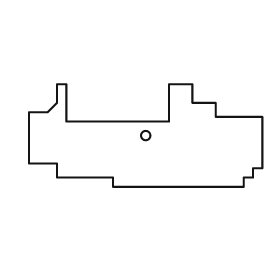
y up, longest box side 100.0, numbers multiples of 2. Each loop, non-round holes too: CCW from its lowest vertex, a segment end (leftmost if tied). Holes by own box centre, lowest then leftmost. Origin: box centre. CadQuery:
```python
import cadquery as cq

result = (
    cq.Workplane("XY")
    .moveTo(-14.0, -22.0)
    .lineTo(42.0, -22.0)
    .lineTo(42.0, -18.0)
    .lineTo(46.0, -18.0)
    .lineTo(46.0, -14.0)
    .lineTo(50.0, -14.0)
    .lineTo(50.0, 8.0)
    .lineTo(30.0, 8.0)
    .lineTo(30.0, 14.0)
    .lineTo(20.0, 14.0)
    .lineTo(20.0, 22.0)
    .lineTo(10.0, 22.0)
    .lineTo(10.0, 6.0)
    .lineTo(-34.0, 6.0)
    .lineTo(-34.0, 22.0)
    .lineTo(-38.0, 22.0)
    .lineTo(-38.0, 14.0)
    .lineTo(-42.0, 10.0)
    .lineTo(-50.0, 10.0)
    .lineTo(-50.0, -12.0)
    .lineTo(-38.0, -12.0)
    .lineTo(-38.0, -18.0)
    .lineTo(-14.0, -18.0)
    .close()
    .moveTo(0.0, 0.0)
    .circle(2.0)
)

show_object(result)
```